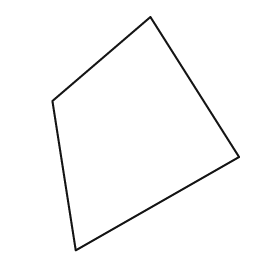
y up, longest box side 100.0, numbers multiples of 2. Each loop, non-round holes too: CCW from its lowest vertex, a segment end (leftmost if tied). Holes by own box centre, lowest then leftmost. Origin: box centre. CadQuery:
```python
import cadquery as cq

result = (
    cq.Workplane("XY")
    .moveTo(-30.0, -50.0)
    .lineTo(40.0, -10.0)
    .lineTo(2.0, 50.0)
    .lineTo(-40.0, 14.0)
    .close()
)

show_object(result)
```